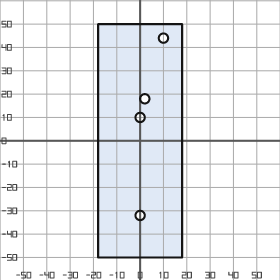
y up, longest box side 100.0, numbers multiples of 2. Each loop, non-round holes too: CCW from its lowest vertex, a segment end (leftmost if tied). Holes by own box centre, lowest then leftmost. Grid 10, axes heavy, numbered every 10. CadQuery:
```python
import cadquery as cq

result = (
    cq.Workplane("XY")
    .moveTo(-18.0, -50.0)
    .lineTo(18.0, -50.0)
    .lineTo(18.0, 50.0)
    .lineTo(-18.0, 50.0)
    .close()
    .moveTo(0.0, -32.0)
    .circle(2.0)
    .moveTo(0.0, 10.0)
    .circle(2.0)
    .moveTo(2.0, 18.0)
    .circle(2.0)
    .moveTo(10.0, 44.0)
    .circle(2.0)
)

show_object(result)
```